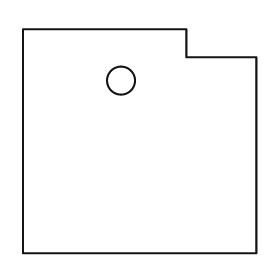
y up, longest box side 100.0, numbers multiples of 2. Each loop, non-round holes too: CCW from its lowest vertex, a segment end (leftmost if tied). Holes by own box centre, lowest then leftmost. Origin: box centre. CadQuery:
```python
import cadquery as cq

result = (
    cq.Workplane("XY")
    .moveTo(-50.0, -48.0)
    .lineTo(50.0, -48.0)
    .lineTo(50.0, 36.0)
    .lineTo(20.0, 36.0)
    .lineTo(20.0, 48.0)
    .lineTo(-50.0, 48.0)
    .close()
    .moveTo(-8.0, 26.0)
    .circle(6.0)
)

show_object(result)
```